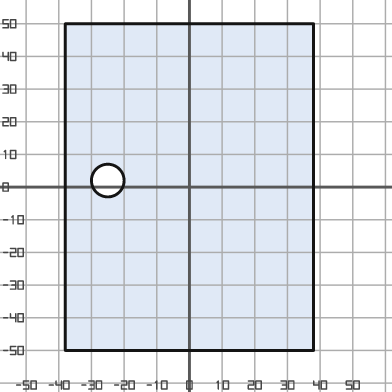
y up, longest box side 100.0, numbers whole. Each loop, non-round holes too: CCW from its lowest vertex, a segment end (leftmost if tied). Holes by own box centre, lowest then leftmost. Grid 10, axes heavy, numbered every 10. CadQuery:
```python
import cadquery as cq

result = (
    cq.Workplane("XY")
    .moveTo(-38.0, -50.0)
    .lineTo(38.0, -50.0)
    .lineTo(38.0, 50.0)
    .lineTo(-38.0, 50.0)
    .close()
    .moveTo(-25.0, 2.0)
    .circle(5.0)
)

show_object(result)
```